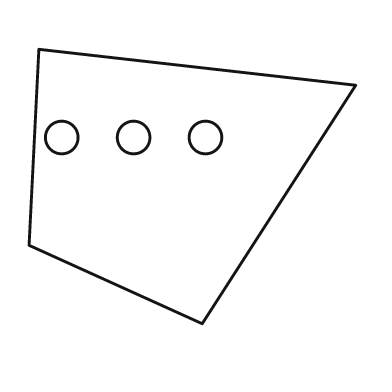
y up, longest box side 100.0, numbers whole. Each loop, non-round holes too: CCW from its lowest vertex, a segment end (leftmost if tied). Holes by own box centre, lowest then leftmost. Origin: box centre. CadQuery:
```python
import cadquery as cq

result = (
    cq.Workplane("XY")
    .moveTo(3.0, -42.0)
    .lineTo(50.0, 31.0)
    .lineTo(-47.0, 42.0)
    .lineTo(-50.0, -18.0)
    .close()
    .moveTo(-40.0, 15.0)
    .circle(5.0)
    .moveTo(-18.0, 15.0)
    .circle(5.0)
    .moveTo(4.0, 15.0)
    .circle(5.0)
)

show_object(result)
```